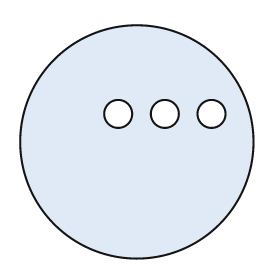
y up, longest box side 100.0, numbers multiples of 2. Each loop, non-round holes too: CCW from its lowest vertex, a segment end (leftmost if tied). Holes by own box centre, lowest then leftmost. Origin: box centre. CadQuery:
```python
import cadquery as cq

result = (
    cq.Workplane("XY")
    .moveTo(0.0, 0.0)
    .circle(50.0)
    .moveTo(-8.0, 12.0)
    .circle(6.0)
    .moveTo(12.0, 12.0)
    .circle(6.0)
    .moveTo(32.0, 12.0)
    .circle(6.0)
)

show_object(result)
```